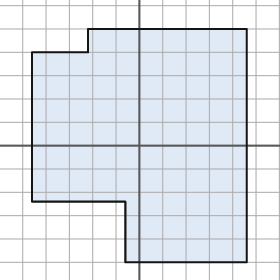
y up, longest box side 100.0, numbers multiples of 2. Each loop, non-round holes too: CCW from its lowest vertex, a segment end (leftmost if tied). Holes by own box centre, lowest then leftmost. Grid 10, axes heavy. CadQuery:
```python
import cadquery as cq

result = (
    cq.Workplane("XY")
    .moveTo(-6.0, -50.0)
    .lineTo(46.0, -50.0)
    .lineTo(46.0, 50.0)
    .lineTo(-22.0, 50.0)
    .lineTo(-22.0, 40.0)
    .lineTo(-46.0, 40.0)
    .lineTo(-46.0, -24.0)
    .lineTo(-6.0, -24.0)
    .close()
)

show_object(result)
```